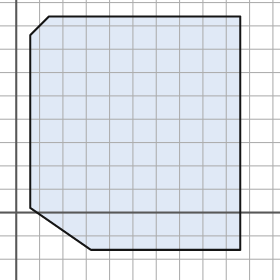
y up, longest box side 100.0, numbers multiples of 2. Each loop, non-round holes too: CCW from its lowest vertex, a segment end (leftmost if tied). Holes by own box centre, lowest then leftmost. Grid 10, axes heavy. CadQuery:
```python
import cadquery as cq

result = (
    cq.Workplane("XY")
    .moveTo(32.0, -16.0)
    .lineTo(96.0, -16.0)
    .lineTo(96.0, 84.0)
    .lineTo(14.0, 84.0)
    .lineTo(6.0, 76.0)
    .lineTo(6.0, 2.0)
    .close()
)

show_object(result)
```